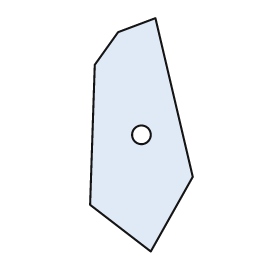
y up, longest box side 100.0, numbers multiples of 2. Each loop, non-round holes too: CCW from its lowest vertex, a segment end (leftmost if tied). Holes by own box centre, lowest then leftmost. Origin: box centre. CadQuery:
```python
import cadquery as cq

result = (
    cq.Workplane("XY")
    .moveTo(4.0, -50.0)
    .lineTo(22.0, -18.0)
    .lineTo(6.0, 50.0)
    .lineTo(-10.0, 44.0)
    .lineTo(-20.0, 30.0)
    .lineTo(-22.0, -30.0)
    .close()
    .moveTo(0.0, 0.0)
    .circle(4.0)
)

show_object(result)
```